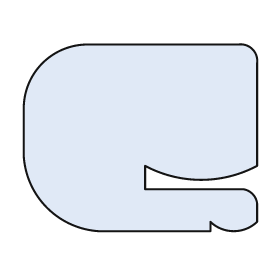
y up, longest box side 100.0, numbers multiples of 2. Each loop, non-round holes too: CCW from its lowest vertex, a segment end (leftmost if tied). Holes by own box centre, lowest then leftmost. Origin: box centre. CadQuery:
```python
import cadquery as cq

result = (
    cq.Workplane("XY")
    .moveTo(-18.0, -40.0)
    .lineTo(30.0, -40.0)
    .lineTo(30.0, -36.0)
    .threePointArc((40.0, -40.0), (50.0, -36.0))
    .lineTo(50.0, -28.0)
    .threePointArc((48.0, -24.0), (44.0, -22.0))
    .lineTo(2.0, -22.0)
    .lineTo(2.0, -12.0)
    .threePointArc((26.0, -18.0), (50.0, -12.0))
    .lineTo(50.0, 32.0)
    .threePointArc((48.0, 38.0), (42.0, 40.0))
    .lineTo(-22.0, 40.0)
    .threePointArc((-42.0, 32.0), (-50.0, 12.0))
    .lineTo(-50.0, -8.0)
    .threePointArc((-40.0, -30.0), (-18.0, -40.0))
    .close()
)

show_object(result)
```